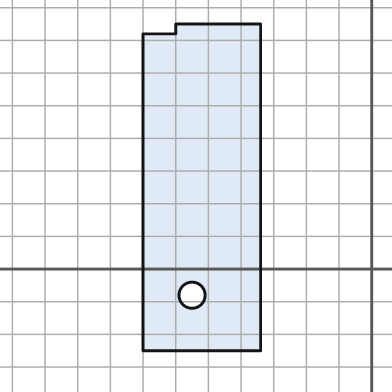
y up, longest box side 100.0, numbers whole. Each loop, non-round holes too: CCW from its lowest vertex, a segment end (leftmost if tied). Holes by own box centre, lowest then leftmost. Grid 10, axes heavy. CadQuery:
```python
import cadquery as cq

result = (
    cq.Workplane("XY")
    .moveTo(-70.0, -25.0)
    .lineTo(-34.0, -25.0)
    .lineTo(-34.0, 75.0)
    .lineTo(-60.0, 75.0)
    .lineTo(-60.0, 72.0)
    .lineTo(-70.0, 72.0)
    .close()
    .moveTo(-55.0, -8.0)
    .circle(4.0)
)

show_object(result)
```